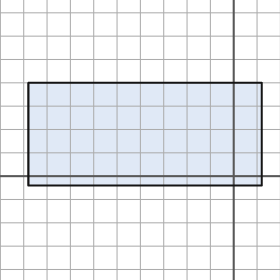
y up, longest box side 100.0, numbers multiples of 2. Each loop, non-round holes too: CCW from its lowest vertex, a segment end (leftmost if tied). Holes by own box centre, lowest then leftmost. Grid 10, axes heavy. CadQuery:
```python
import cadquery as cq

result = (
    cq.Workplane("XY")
    .moveTo(-88.0, -4.0)
    .lineTo(12.0, -4.0)
    .lineTo(12.0, 40.0)
    .lineTo(-88.0, 40.0)
    .close()
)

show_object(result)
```